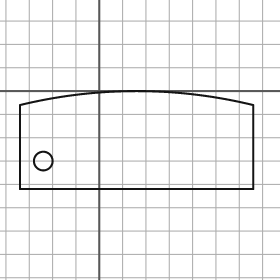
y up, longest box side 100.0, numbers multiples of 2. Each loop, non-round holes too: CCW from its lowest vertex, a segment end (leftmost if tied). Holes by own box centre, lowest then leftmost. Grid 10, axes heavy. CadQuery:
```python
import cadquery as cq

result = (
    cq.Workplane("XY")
    .moveTo(-34.0, -42.0)
    .lineTo(66.0, -42.0)
    .lineTo(66.0, -6.0)
    .threePointArc((16.0, 0.0), (-34.0, -6.0))
    .close()
    .moveTo(-24.0, -30.0)
    .circle(4.0)
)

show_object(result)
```